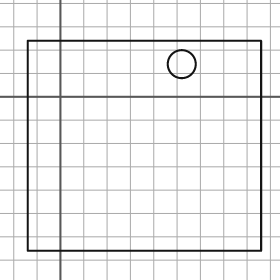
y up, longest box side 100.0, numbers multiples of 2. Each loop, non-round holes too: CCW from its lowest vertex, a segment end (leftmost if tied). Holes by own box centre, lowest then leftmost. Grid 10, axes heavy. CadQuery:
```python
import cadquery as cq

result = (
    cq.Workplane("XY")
    .moveTo(-14.0, -66.0)
    .lineTo(86.0, -66.0)
    .lineTo(86.0, 24.0)
    .lineTo(-14.0, 24.0)
    .close()
    .moveTo(52.0, 14.0)
    .circle(6.0)
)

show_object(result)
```